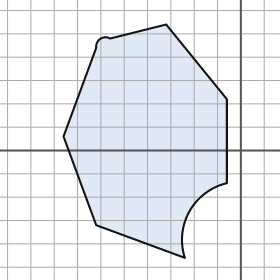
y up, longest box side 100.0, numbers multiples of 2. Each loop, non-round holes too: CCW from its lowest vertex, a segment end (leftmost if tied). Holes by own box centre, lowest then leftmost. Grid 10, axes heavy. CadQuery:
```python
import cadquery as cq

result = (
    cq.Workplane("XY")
    .moveTo(-24.0, -46.0)
    .threePointArc((-22.0, -26.0), (-6.0, -14.0))
    .lineTo(-6.0, 22.0)
    .lineTo(-32.0, 54.0)
    .lineTo(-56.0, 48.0)
    .threePointArc((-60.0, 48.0), (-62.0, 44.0))
    .lineTo(-76.0, 6.0)
    .lineTo(-62.0, -32.0)
    .close()
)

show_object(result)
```